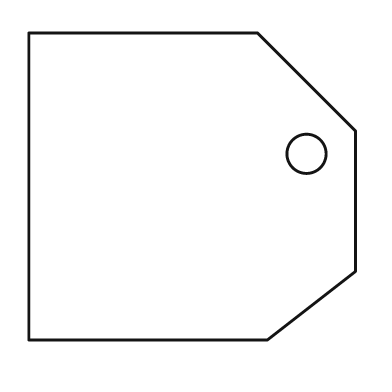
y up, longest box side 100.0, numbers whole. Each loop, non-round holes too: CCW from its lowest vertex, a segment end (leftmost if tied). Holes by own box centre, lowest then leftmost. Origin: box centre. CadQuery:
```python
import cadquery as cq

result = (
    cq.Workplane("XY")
    .moveTo(-50.0, -47.0)
    .lineTo(23.0, -47.0)
    .lineTo(50.0, -26.0)
    .lineTo(50.0, 17.0)
    .lineTo(20.0, 47.0)
    .lineTo(-50.0, 47.0)
    .close()
    .moveTo(35.0, 10.0)
    .circle(6.0)
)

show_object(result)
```